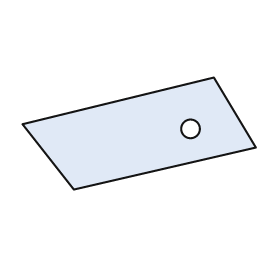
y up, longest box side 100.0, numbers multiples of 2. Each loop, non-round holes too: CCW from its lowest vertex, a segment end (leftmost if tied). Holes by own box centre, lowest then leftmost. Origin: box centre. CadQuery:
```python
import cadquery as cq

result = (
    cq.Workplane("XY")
    .moveTo(-28.0, -24.0)
    .lineTo(50.0, -6.0)
    .lineTo(32.0, 24.0)
    .lineTo(-50.0, 4.0)
    .close()
    .moveTo(22.0, 2.0)
    .circle(4.0)
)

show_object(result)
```